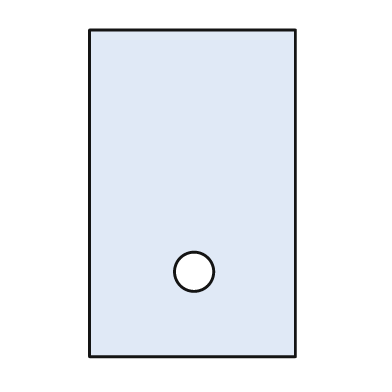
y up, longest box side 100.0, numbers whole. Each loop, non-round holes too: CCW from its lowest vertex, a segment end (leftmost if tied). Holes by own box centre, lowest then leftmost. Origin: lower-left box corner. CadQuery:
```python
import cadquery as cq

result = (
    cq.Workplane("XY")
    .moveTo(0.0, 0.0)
    .lineTo(63.0, 0.0)
    .lineTo(63.0, 100.0)
    .lineTo(0.0, 100.0)
    .close()
    .moveTo(32.0, 26.0)
    .circle(6.0)
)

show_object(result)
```